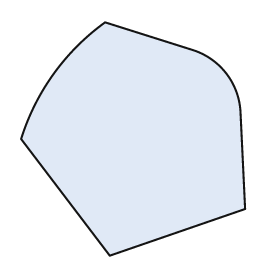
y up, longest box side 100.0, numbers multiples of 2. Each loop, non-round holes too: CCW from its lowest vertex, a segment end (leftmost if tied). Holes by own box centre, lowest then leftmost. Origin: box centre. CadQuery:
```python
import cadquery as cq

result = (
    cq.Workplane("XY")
    .moveTo(-10.0, -50.0)
    .lineTo(48.0, -30.0)
    .lineTo(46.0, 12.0)
    .threePointArc((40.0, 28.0), (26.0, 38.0))
    .lineTo(-12.0, 50.0)
    .threePointArc((-34.0, 28.0), (-48.0, 0.0))
    .close()
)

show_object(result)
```